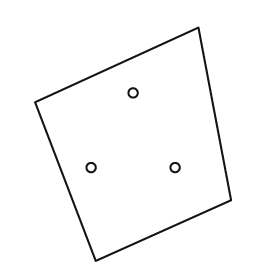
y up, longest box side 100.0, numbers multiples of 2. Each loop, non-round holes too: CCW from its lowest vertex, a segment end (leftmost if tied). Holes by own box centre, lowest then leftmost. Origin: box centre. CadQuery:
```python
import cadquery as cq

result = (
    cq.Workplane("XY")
    .moveTo(-16.0, -50.0)
    .lineTo(42.0, -24.0)
    .lineTo(28.0, 50.0)
    .lineTo(-42.0, 18.0)
    .close()
    .moveTo(-18.0, -10.0)
    .circle(2.0)
    .moveTo(18.0, -10.0)
    .circle(2.0)
    .moveTo(0.0, 22.0)
    .circle(2.0)
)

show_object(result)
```